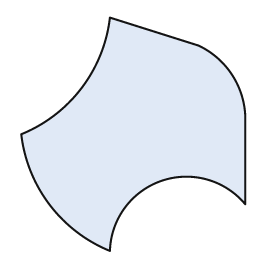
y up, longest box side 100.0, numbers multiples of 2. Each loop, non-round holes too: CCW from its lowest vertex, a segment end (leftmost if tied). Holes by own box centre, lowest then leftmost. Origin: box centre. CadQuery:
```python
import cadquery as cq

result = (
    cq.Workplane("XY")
    .moveTo(-10.0, -50.0)
    .threePointArc((12.0, -20.0), (48.0, -30.0))
    .lineTo(48.0, 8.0)
    .threePointArc((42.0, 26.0), (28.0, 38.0))
    .lineTo(-10.0, 50.0)
    .threePointArc((-22.0, 20.0), (-48.0, 0.0))
    .threePointArc((-36.0, -30.0), (-10.0, -50.0))
    .close()
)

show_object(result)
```